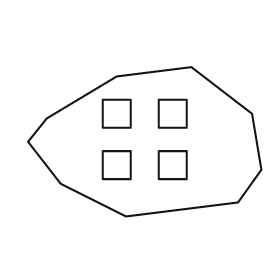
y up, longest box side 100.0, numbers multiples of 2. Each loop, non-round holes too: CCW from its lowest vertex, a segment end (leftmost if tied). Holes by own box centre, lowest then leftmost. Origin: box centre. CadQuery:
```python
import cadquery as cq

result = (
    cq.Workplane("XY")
    .moveTo(-8.0, -32.0)
    .lineTo(40.0, -26.0)
    .lineTo(50.0, -12.0)
    .lineTo(46.0, 12.0)
    .lineTo(20.0, 32.0)
    .lineTo(-12.0, 28.0)
    .lineTo(-42.0, 10.0)
    .lineTo(-50.0, 0.0)
    .lineTo(-36.0, -18.0)
    .close()
    .moveTo(-18.0, -16.0)
    .lineTo(-6.0, -16.0)
    .lineTo(-6.0, -4.0)
    .lineTo(-18.0, -4.0)
    .close()
    .moveTo(6.0, -16.0)
    .lineTo(18.0, -16.0)
    .lineTo(18.0, -4.0)
    .lineTo(6.0, -4.0)
    .close()
    .moveTo(-18.0, 6.0)
    .lineTo(-6.0, 6.0)
    .lineTo(-6.0, 18.0)
    .lineTo(-18.0, 18.0)
    .close()
    .moveTo(6.0, 6.0)
    .lineTo(18.0, 6.0)
    .lineTo(18.0, 18.0)
    .lineTo(6.0, 18.0)
    .close()
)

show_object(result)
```